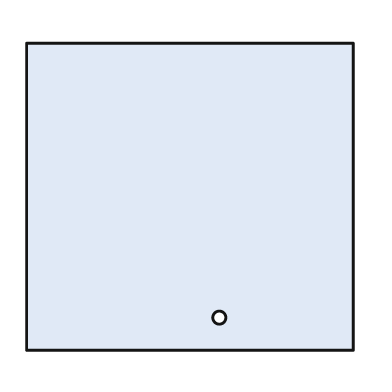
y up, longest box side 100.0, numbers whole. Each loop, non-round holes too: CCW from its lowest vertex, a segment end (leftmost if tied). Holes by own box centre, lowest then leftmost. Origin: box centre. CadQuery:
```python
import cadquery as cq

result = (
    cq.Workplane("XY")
    .moveTo(-50.0, -47.0)
    .lineTo(50.0, -47.0)
    .lineTo(50.0, 47.0)
    .lineTo(-50.0, 47.0)
    .close()
    .moveTo(9.0, -37.0)
    .circle(2.0)
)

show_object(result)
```